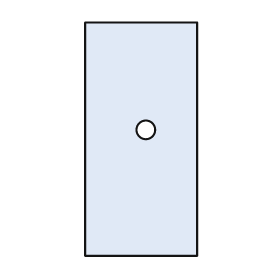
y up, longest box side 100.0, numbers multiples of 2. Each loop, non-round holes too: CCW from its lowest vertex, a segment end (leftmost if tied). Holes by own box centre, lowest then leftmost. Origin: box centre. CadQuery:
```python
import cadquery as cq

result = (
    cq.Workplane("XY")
    .moveTo(-24.0, -50.0)
    .lineTo(24.0, -50.0)
    .lineTo(24.0, 50.0)
    .lineTo(-24.0, 50.0)
    .close()
    .moveTo(2.0, 4.0)
    .circle(4.0)
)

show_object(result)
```